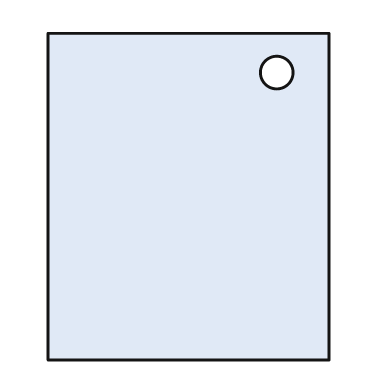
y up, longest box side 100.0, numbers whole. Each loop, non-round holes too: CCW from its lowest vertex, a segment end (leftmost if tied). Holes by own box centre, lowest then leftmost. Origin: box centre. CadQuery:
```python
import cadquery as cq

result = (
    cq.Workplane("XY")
    .moveTo(-43.0, -50.0)
    .lineTo(43.0, -50.0)
    .lineTo(43.0, 50.0)
    .lineTo(-43.0, 50.0)
    .close()
    .moveTo(27.0, 38.0)
    .circle(5.0)
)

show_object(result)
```